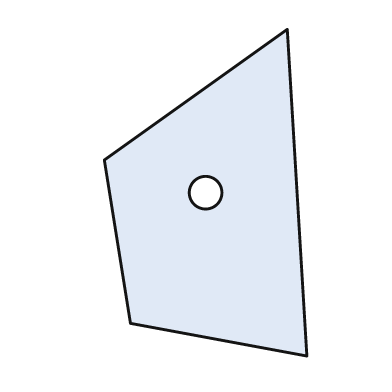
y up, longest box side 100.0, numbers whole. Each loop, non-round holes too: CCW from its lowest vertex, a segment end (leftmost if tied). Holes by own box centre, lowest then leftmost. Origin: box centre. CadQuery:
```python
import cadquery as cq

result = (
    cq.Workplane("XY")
    .moveTo(31.0, -50.0)
    .lineTo(25.0, 50.0)
    .lineTo(-31.0, 10.0)
    .lineTo(-23.0, -40.0)
    .close()
    .moveTo(0.0, 0.0)
    .circle(5.0)
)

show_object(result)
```